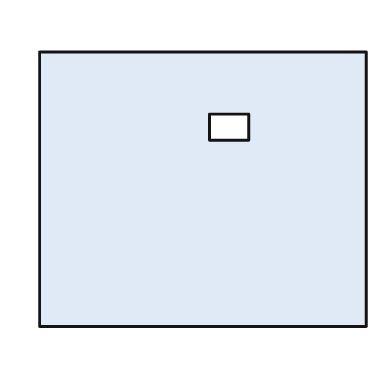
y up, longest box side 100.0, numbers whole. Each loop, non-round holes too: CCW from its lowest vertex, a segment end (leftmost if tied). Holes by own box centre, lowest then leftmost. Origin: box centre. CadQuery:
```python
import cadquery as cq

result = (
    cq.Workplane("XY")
    .moveTo(-50.0, -42.0)
    .lineTo(50.0, -42.0)
    .lineTo(50.0, 42.0)
    .lineTo(-50.0, 42.0)
    .close()
    .moveTo(2.0, 15.0)
    .lineTo(14.0, 15.0)
    .lineTo(14.0, 23.0)
    .lineTo(2.0, 23.0)
    .close()
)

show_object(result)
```